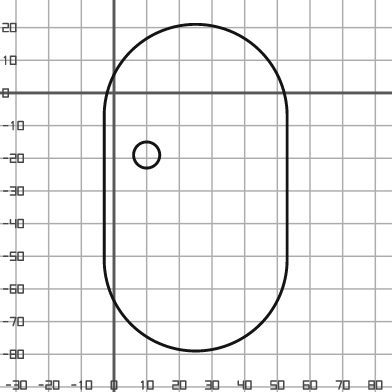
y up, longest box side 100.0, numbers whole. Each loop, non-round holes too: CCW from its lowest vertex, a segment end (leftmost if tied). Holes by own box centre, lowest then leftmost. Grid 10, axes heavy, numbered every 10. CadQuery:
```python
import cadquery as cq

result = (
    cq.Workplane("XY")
    .moveTo(-3.0, -51.0)
    .threePointArc((25.0, -79.0), (53.0, -51.0))
    .lineTo(53.0, -7.0)
    .threePointArc((25.0, 21.0), (-3.0, -7.0))
    .close()
    .moveTo(10.0, -19.0)
    .circle(4.0)
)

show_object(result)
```